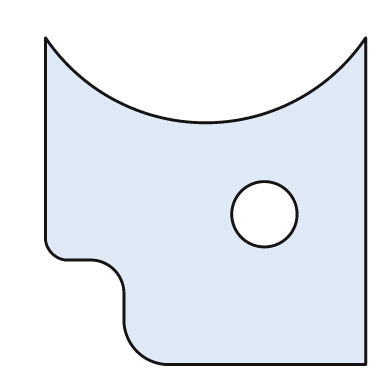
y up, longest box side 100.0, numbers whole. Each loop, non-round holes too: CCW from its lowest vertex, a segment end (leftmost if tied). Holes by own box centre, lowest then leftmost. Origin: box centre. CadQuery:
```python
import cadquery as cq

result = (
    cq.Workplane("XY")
    .moveTo(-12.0, -50.0)
    .lineTo(49.0, -50.0)
    .lineTo(49.0, 50.0)
    .threePointArc((0.0, 24.0), (-49.0, 50.0))
    .lineTo(-49.0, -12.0)
    .threePointArc((-47.0, -16.0), (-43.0, -18.0))
    .lineTo(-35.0, -18.0)
    .threePointArc((-28.0, -21.0), (-25.0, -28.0))
    .lineTo(-25.0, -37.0)
    .threePointArc((-21.0, -46.0), (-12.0, -50.0))
    .close()
    .moveTo(18.0, -4.0)
    .circle(10.0)
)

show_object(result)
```